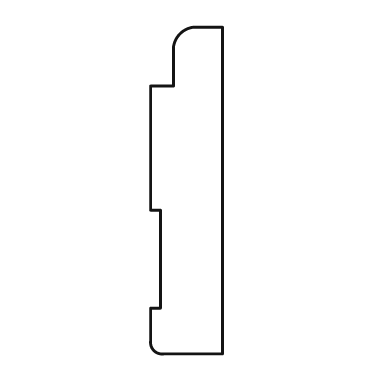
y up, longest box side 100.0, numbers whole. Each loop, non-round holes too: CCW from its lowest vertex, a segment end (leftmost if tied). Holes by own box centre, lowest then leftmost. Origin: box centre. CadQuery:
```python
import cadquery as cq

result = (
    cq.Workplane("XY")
    .moveTo(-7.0, -50.0)
    .lineTo(11.0, -50.0)
    .lineTo(11.0, 50.0)
    .lineTo(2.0, 50.0)
    .threePointArc((-2.0, 48.0), (-4.0, 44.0))
    .lineTo(-4.0, 32.0)
    .lineTo(-11.0, 32.0)
    .lineTo(-11.0, -6.0)
    .lineTo(-8.0, -6.0)
    .lineTo(-8.0, -36.0)
    .lineTo(-11.0, -36.0)
    .lineTo(-11.0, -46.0)
    .threePointArc((-10.0, -49.0), (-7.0, -50.0))
    .close()
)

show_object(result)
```